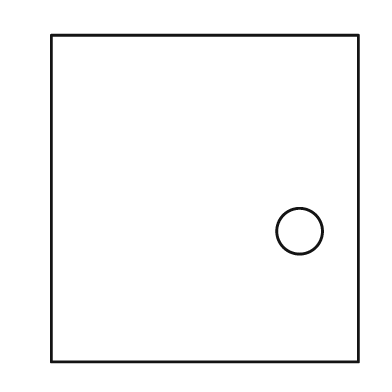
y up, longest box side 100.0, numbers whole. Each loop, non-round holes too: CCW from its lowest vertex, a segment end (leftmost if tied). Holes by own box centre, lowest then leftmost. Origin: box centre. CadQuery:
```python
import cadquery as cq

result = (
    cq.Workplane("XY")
    .moveTo(-47.0, -50.0)
    .lineTo(47.0, -50.0)
    .lineTo(47.0, 50.0)
    .lineTo(-47.0, 50.0)
    .close()
    .moveTo(29.0, -10.0)
    .circle(7.0)
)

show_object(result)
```